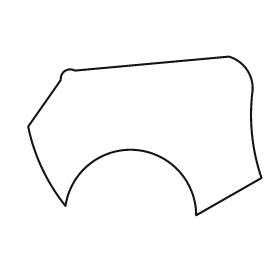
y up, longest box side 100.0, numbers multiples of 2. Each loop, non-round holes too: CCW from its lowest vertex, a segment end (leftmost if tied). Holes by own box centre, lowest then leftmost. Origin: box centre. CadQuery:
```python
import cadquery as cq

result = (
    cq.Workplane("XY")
    .moveTo(22.0, -34.0)
    .lineTo(50.0, -18.0)
    .threePointArc((46.0, 0.0), (46.0, 18.0))
    .threePointArc((44.0, 28.0), (36.0, 34.0))
    .lineTo(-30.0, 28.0)
    .threePointArc((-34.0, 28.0), (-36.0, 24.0))
    .lineTo(-50.0, 4.0)
    .threePointArc((-44.0, -14.0), (-34.0, -30.0))
    .threePointArc((-4.0, -6.0), (22.0, -34.0))
    .close()
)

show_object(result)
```